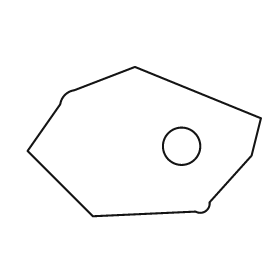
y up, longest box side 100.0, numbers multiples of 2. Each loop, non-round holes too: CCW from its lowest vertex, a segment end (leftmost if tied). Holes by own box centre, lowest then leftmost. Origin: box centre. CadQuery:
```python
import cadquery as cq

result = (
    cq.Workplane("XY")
    .moveTo(-22.0, -32.0)
    .lineTo(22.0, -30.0)
    .threePointArc((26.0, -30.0), (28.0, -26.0))
    .lineTo(46.0, -6.0)
    .lineTo(50.0, 10.0)
    .lineTo(-4.0, 32.0)
    .lineTo(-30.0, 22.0)
    .threePointArc((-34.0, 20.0), (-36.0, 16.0))
    .lineTo(-50.0, -4.0)
    .close()
    .moveTo(16.0, -2.0)
    .circle(8.0)
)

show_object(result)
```